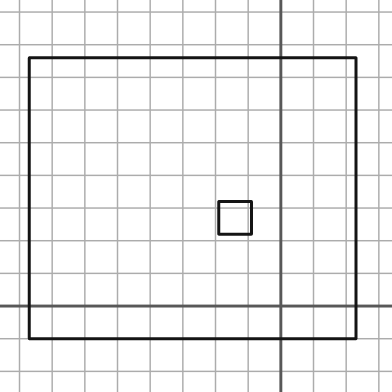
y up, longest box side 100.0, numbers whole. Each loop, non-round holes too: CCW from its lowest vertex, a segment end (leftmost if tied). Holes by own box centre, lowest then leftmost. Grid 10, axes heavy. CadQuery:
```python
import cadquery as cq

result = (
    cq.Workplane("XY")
    .moveTo(-77.0, -10.0)
    .lineTo(23.0, -10.0)
    .lineTo(23.0, 76.0)
    .lineTo(-77.0, 76.0)
    .close()
    .moveTo(-19.0, 22.0)
    .lineTo(-9.0, 22.0)
    .lineTo(-9.0, 32.0)
    .lineTo(-19.0, 32.0)
    .close()
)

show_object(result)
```